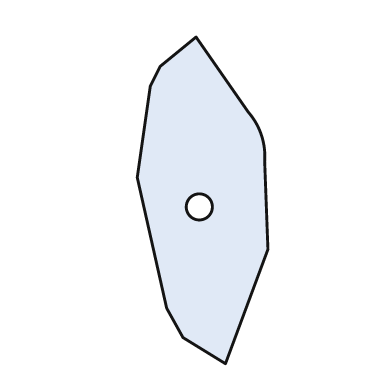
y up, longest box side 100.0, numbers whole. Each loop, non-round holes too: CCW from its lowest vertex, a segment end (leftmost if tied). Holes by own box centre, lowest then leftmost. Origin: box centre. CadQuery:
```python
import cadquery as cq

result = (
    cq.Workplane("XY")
    .moveTo(7.0, -50.0)
    .lineTo(20.0, -15.0)
    .lineTo(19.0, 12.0)
    .threePointArc((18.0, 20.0), (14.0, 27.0))
    .lineTo(-2.0, 50.0)
    .lineTo(-13.0, 41.0)
    .lineTo(-16.0, 35.0)
    .lineTo(-20.0, 7.0)
    .lineTo(-11.0, -33.0)
    .lineTo(-6.0, -42.0)
    .close()
    .moveTo(-1.0, -2.0)
    .circle(4.0)
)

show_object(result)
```